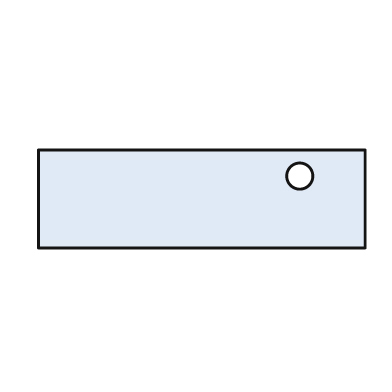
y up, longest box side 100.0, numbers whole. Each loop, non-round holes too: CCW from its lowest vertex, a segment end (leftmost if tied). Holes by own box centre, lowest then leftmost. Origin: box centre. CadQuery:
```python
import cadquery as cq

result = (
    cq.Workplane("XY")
    .moveTo(-50.0, -15.0)
    .lineTo(50.0, -15.0)
    .lineTo(50.0, 15.0)
    .lineTo(-50.0, 15.0)
    .close()
    .moveTo(30.0, 7.0)
    .circle(4.0)
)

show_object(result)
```